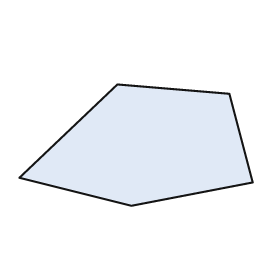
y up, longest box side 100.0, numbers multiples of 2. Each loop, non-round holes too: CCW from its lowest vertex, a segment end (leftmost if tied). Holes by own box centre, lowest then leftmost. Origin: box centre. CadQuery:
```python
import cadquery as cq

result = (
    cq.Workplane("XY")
    .moveTo(-2.0, -26.0)
    .lineTo(50.0, -16.0)
    .lineTo(40.0, 22.0)
    .lineTo(-8.0, 26.0)
    .lineTo(-50.0, -14.0)
    .close()
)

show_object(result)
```